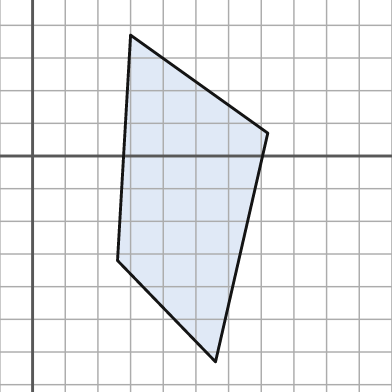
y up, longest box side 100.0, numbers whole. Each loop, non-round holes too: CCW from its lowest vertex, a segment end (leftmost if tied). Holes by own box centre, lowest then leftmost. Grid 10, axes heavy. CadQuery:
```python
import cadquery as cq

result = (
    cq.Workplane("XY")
    .moveTo(56.0, -63.0)
    .lineTo(72.0, 7.0)
    .lineTo(30.0, 37.0)
    .lineTo(26.0, -32.0)
    .close()
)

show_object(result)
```